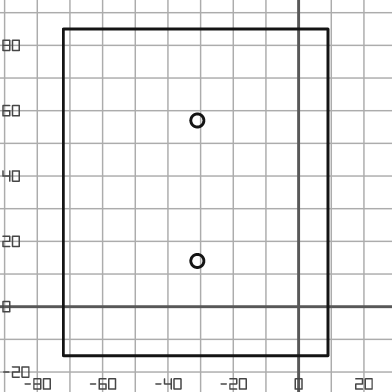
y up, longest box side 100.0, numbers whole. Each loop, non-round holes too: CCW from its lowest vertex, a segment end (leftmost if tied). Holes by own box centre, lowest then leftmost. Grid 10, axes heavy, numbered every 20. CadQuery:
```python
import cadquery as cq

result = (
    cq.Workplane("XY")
    .moveTo(-72.0, -15.0)
    .lineTo(9.0, -15.0)
    .lineTo(9.0, 85.0)
    .lineTo(-72.0, 85.0)
    .close()
    .moveTo(-31.0, 14.0)
    .circle(2.0)
    .moveTo(-31.0, 57.0)
    .circle(2.0)
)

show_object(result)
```